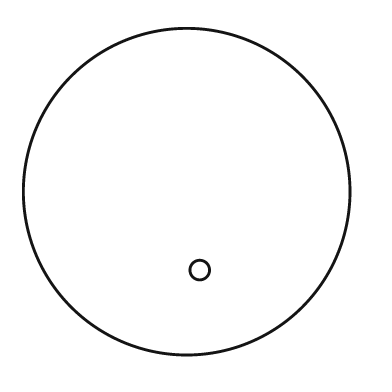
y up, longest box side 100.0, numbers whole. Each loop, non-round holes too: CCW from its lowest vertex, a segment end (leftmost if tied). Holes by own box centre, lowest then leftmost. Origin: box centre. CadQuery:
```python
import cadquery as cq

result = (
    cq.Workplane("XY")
    .moveTo(0.0, 0.0)
    .circle(50.0)
    .moveTo(4.0, -24.0)
    .circle(3.0)
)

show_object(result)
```